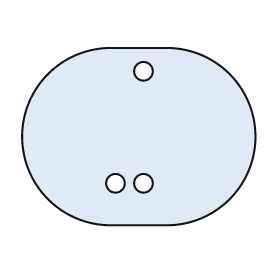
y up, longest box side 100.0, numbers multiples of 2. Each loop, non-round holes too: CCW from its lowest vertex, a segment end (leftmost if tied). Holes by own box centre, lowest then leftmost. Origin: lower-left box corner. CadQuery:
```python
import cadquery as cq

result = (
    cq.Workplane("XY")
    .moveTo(38.0, 0.0)
    .lineTo(62.0, 0.0)
    .threePointArc((100.0, 38.0), (62.0, 76.0))
    .lineTo(38.0, 76.0)
    .threePointArc((0.0, 38.0), (38.0, 0.0))
    .close()
    .moveTo(40.0, 18.0)
    .circle(4.0)
    .moveTo(52.0, 18.0)
    .circle(4.0)
    .moveTo(52.0, 66.0)
    .circle(4.0)
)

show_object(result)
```